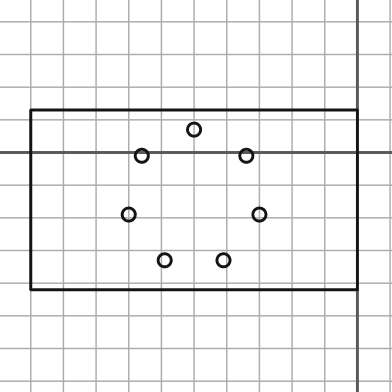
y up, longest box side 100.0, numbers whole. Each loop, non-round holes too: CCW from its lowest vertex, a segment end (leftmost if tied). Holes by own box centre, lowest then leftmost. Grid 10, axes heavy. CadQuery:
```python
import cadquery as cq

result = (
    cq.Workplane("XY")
    .moveTo(-100.0, -42.0)
    .lineTo(0.0, -42.0)
    .lineTo(0.0, 13.0)
    .lineTo(-100.0, 13.0)
    .close()
    .moveTo(-59.0, -33.0)
    .circle(2.0)
    .moveTo(-41.0, -33.0)
    .circle(2.0)
    .moveTo(-70.0, -19.0)
    .circle(2.0)
    .moveTo(-30.0, -19.0)
    .circle(2.0)
    .moveTo(-66.0, -1.0)
    .circle(2.0)
    .moveTo(-34.0, -1.0)
    .circle(2.0)
    .moveTo(-50.0, 7.0)
    .circle(2.0)
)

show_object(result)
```